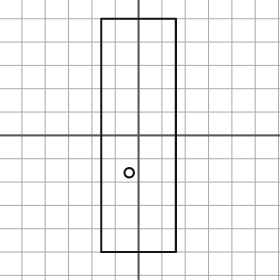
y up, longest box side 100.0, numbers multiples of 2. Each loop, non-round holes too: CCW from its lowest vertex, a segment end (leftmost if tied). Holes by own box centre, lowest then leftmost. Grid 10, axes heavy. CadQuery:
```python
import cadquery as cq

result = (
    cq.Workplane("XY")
    .moveTo(-16.0, -50.0)
    .lineTo(16.0, -50.0)
    .lineTo(16.0, 50.0)
    .lineTo(-16.0, 50.0)
    .close()
    .moveTo(-4.0, -16.0)
    .circle(2.0)
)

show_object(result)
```